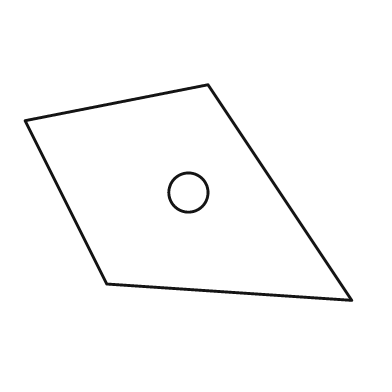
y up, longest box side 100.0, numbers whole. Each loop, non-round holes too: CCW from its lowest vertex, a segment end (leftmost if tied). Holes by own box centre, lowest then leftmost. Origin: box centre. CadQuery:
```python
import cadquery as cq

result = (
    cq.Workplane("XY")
    .moveTo(50.0, -33.0)
    .lineTo(6.0, 33.0)
    .lineTo(-50.0, 22.0)
    .lineTo(-25.0, -28.0)
    .close()
    .moveTo(0.0, 0.0)
    .circle(6.0)
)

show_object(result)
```